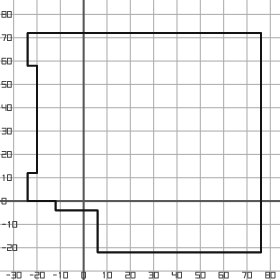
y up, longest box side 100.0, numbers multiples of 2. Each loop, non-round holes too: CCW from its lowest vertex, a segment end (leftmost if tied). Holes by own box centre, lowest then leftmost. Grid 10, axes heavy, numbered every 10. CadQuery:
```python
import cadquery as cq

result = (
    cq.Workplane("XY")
    .moveTo(6.0, -22.0)
    .lineTo(76.0, -22.0)
    .lineTo(76.0, 72.0)
    .lineTo(-24.0, 72.0)
    .lineTo(-24.0, 58.0)
    .lineTo(-20.0, 58.0)
    .lineTo(-20.0, 12.0)
    .lineTo(-24.0, 12.0)
    .lineTo(-24.0, 0.0)
    .lineTo(-12.0, 0.0)
    .lineTo(-12.0, -4.0)
    .lineTo(6.0, -4.0)
    .close()
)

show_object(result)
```